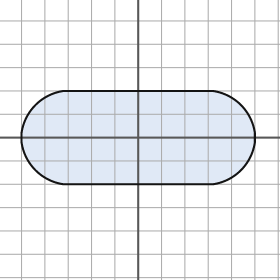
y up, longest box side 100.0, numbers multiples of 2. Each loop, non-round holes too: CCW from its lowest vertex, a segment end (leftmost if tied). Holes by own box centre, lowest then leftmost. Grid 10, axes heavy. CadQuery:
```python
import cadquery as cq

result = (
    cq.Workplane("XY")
    .moveTo(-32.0, -20.0)
    .lineTo(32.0, -20.0)
    .threePointArc((44.0, -14.0), (50.0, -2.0))
    .lineTo(50.0, 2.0)
    .threePointArc((44.0, 14.0), (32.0, 20.0))
    .lineTo(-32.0, 20.0)
    .threePointArc((-44.0, 14.0), (-50.0, 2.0))
    .lineTo(-50.0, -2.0)
    .threePointArc((-44.0, -14.0), (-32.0, -20.0))
    .close()
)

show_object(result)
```